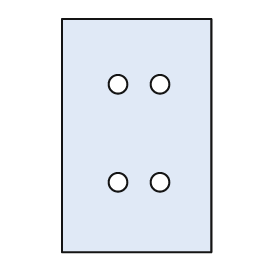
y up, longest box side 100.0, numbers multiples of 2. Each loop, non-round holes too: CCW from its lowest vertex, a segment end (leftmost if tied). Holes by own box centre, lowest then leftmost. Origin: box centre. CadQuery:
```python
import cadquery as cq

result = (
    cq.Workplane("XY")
    .moveTo(-32.0, -50.0)
    .lineTo(32.0, -50.0)
    .lineTo(32.0, 50.0)
    .lineTo(-32.0, 50.0)
    .close()
    .moveTo(-8.0, -20.0)
    .circle(4.0)
    .moveTo(10.0, -20.0)
    .circle(4.0)
    .moveTo(-8.0, 22.0)
    .circle(4.0)
    .moveTo(10.0, 22.0)
    .circle(4.0)
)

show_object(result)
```